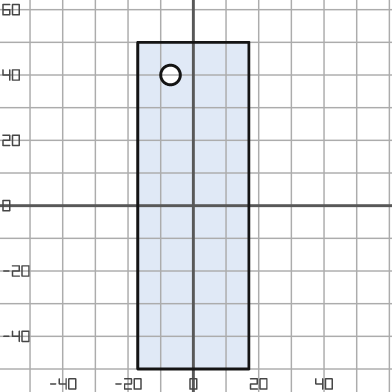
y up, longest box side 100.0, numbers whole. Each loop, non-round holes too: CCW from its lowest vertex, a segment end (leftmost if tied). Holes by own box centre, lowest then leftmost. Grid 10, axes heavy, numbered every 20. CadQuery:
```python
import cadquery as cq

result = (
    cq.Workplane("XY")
    .moveTo(-17.0, -50.0)
    .lineTo(17.0, -50.0)
    .lineTo(17.0, 50.0)
    .lineTo(-17.0, 50.0)
    .close()
    .moveTo(-7.0, 40.0)
    .circle(3.0)
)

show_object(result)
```